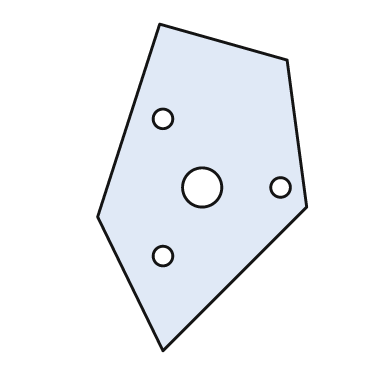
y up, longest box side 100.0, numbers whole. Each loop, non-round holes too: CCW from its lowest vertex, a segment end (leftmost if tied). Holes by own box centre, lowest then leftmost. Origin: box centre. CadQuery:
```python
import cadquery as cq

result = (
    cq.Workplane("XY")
    .moveTo(-12.0, -50.0)
    .lineTo(32.0, -6.0)
    .lineTo(26.0, 39.0)
    .lineTo(-13.0, 50.0)
    .lineTo(-32.0, -9.0)
    .close()
    .moveTo(-12.0, -21.0)
    .circle(3.0)
    .moveTo(0.0, 0.0)
    .circle(6.0)
    .moveTo(24.0, 0.0)
    .circle(3.0)
    .moveTo(-12.0, 21.0)
    .circle(3.0)
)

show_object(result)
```